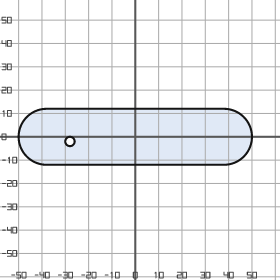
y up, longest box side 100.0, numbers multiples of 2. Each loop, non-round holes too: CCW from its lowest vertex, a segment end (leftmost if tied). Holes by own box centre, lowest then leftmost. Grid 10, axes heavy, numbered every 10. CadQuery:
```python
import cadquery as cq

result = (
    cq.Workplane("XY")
    .moveTo(-38.0, -12.0)
    .lineTo(38.0, -12.0)
    .threePointArc((50.0, 0.0), (38.0, 12.0))
    .lineTo(-38.0, 12.0)
    .threePointArc((-50.0, 0.0), (-38.0, -12.0))
    .close()
    .moveTo(-28.0, -2.0)
    .circle(2.0)
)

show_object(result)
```